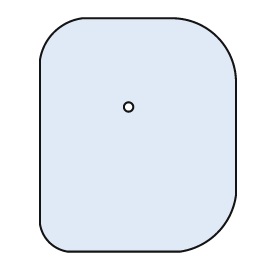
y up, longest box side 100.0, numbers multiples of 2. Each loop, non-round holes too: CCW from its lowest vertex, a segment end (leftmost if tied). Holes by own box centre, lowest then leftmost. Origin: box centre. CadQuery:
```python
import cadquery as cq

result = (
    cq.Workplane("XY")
    .moveTo(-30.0, -50.0)
    .lineTo(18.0, -50.0)
    .threePointArc((34.0, -42.0), (42.0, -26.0))
    .lineTo(42.0, 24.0)
    .threePointArc((34.0, 42.0), (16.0, 50.0))
    .lineTo(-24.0, 50.0)
    .threePointArc((-36.0, 44.0), (-42.0, 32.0))
    .lineTo(-42.0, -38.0)
    .threePointArc((-38.0, -46.0), (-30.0, -50.0))
    .close()
    .moveTo(-4.0, 12.0)
    .circle(2.0)
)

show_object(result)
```